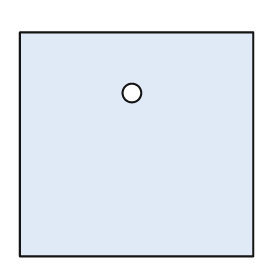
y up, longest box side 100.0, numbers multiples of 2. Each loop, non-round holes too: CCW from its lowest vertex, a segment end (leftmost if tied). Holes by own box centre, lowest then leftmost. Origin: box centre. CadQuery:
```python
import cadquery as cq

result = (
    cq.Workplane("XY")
    .moveTo(-50.0, -48.0)
    .lineTo(50.0, -48.0)
    .lineTo(50.0, 48.0)
    .lineTo(-50.0, 48.0)
    .close()
    .moveTo(-2.0, 22.0)
    .circle(4.0)
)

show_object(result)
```